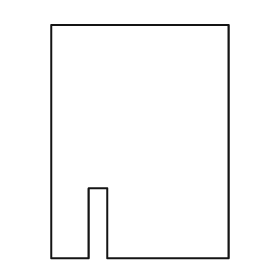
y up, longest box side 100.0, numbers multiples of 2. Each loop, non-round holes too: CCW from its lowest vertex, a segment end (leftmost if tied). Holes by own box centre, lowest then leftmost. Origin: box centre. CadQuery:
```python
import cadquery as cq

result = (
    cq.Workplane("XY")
    .moveTo(-38.0, -50.0)
    .lineTo(-22.0, -50.0)
    .lineTo(-22.0, -20.0)
    .lineTo(-14.0, -20.0)
    .lineTo(-14.0, -50.0)
    .lineTo(38.0, -50.0)
    .lineTo(38.0, 50.0)
    .lineTo(-38.0, 50.0)
    .close()
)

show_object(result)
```